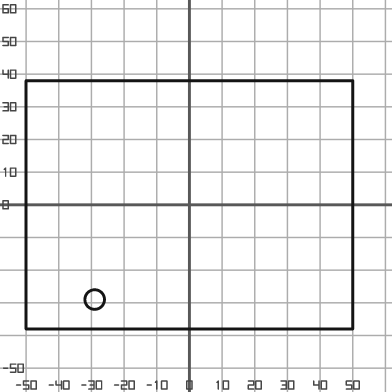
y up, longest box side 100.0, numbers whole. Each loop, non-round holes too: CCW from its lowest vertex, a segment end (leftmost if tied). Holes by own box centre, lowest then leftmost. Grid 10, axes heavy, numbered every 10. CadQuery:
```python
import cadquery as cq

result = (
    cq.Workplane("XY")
    .moveTo(-50.0, -38.0)
    .lineTo(50.0, -38.0)
    .lineTo(50.0, 38.0)
    .lineTo(-50.0, 38.0)
    .close()
    .moveTo(-29.0, -29.0)
    .circle(3.0)
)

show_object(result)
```